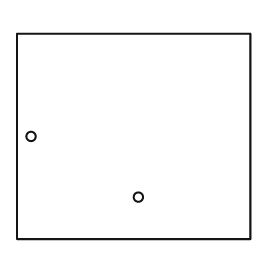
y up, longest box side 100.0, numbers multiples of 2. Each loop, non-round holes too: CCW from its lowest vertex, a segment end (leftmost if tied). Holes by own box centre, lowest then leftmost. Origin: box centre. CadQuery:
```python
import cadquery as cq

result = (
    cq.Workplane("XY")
    .moveTo(-50.0, -44.0)
    .lineTo(50.0, -44.0)
    .lineTo(50.0, 44.0)
    .lineTo(-50.0, 44.0)
    .close()
    .moveTo(2.0, -26.0)
    .circle(2.0)
    .moveTo(-44.0, 0.0)
    .circle(2.0)
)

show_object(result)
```